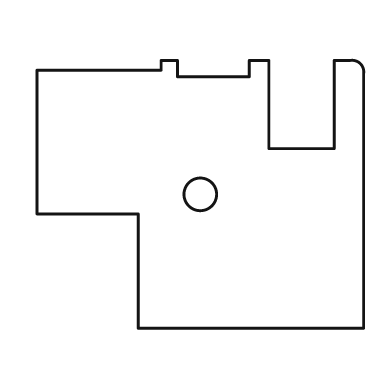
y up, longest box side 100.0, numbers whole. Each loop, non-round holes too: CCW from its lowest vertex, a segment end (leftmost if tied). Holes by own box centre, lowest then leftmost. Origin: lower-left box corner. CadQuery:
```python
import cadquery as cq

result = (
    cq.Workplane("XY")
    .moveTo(31.0, 0.0)
    .lineTo(100.0, 0.0)
    .lineTo(100.0, 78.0)
    .threePointArc((99.0, 81.0), (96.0, 82.0))
    .lineTo(91.0, 82.0)
    .lineTo(91.0, 55.0)
    .lineTo(71.0, 55.0)
    .lineTo(71.0, 82.0)
    .lineTo(65.0, 82.0)
    .lineTo(65.0, 77.0)
    .lineTo(43.0, 77.0)
    .lineTo(43.0, 82.0)
    .lineTo(38.0, 82.0)
    .lineTo(38.0, 79.0)
    .lineTo(0.0, 79.0)
    .lineTo(0.0, 35.0)
    .lineTo(31.0, 35.0)
    .close()
    .moveTo(50.0, 41.0)
    .circle(5.0)
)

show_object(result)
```